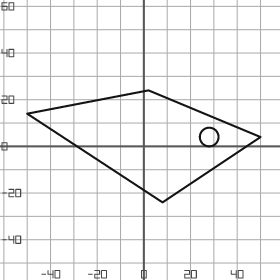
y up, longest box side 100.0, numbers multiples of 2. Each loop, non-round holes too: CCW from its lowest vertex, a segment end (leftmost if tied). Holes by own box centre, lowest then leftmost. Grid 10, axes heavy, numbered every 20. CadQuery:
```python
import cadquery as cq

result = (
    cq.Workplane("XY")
    .moveTo(8.0, -24.0)
    .lineTo(50.0, 4.0)
    .lineTo(2.0, 24.0)
    .lineTo(-50.0, 14.0)
    .close()
    .moveTo(28.0, 4.0)
    .circle(4.0)
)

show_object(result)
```